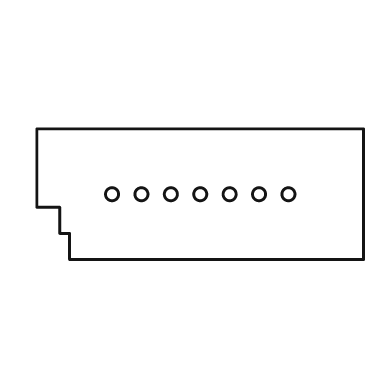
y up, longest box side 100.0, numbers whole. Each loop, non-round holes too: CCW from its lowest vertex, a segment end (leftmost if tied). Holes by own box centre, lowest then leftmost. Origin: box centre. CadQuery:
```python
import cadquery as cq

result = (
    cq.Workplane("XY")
    .moveTo(-40.0, -20.0)
    .lineTo(50.0, -20.0)
    .lineTo(50.0, 20.0)
    .lineTo(-50.0, 20.0)
    .lineTo(-50.0, -4.0)
    .lineTo(-43.0, -4.0)
    .lineTo(-43.0, -12.0)
    .lineTo(-40.0, -12.0)
    .close()
    .moveTo(-27.0, 0.0)
    .circle(2.0)
    .moveTo(-18.0, 0.0)
    .circle(2.0)
    .moveTo(-9.0, 0.0)
    .circle(2.0)
    .moveTo(0.0, 0.0)
    .circle(2.0)
    .moveTo(9.0, 0.0)
    .circle(2.0)
    .moveTo(18.0, 0.0)
    .circle(2.0)
    .moveTo(27.0, 0.0)
    .circle(2.0)
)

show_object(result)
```